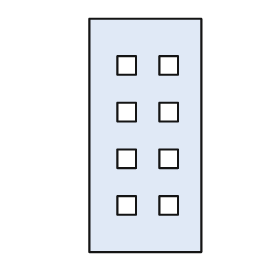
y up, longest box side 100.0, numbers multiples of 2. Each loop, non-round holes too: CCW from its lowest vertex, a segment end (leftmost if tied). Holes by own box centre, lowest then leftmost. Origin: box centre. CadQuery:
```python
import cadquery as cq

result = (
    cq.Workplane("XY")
    .moveTo(-24.0, -50.0)
    .lineTo(24.0, -50.0)
    .lineTo(24.0, 50.0)
    .lineTo(-24.0, 50.0)
    .close()
    .moveTo(-12.0, -34.0)
    .lineTo(-4.0, -34.0)
    .lineTo(-4.0, -26.0)
    .lineTo(-12.0, -26.0)
    .close()
    .moveTo(6.0, -34.0)
    .lineTo(14.0, -34.0)
    .lineTo(14.0, -26.0)
    .lineTo(6.0, -26.0)
    .close()
    .moveTo(-12.0, -14.0)
    .lineTo(-4.0, -14.0)
    .lineTo(-4.0, -6.0)
    .lineTo(-12.0, -6.0)
    .close()
    .moveTo(6.0, -14.0)
    .lineTo(14.0, -14.0)
    .lineTo(14.0, -6.0)
    .lineTo(6.0, -6.0)
    .close()
    .moveTo(-12.0, 6.0)
    .lineTo(-4.0, 6.0)
    .lineTo(-4.0, 14.0)
    .lineTo(-12.0, 14.0)
    .close()
    .moveTo(6.0, 6.0)
    .lineTo(14.0, 6.0)
    .lineTo(14.0, 14.0)
    .lineTo(6.0, 14.0)
    .close()
    .moveTo(-12.0, 26.0)
    .lineTo(-4.0, 26.0)
    .lineTo(-4.0, 34.0)
    .lineTo(-12.0, 34.0)
    .close()
    .moveTo(6.0, 26.0)
    .lineTo(14.0, 26.0)
    .lineTo(14.0, 34.0)
    .lineTo(6.0, 34.0)
    .close()
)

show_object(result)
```